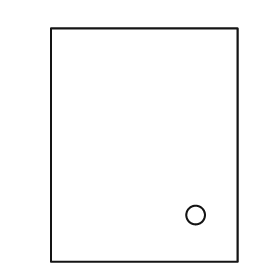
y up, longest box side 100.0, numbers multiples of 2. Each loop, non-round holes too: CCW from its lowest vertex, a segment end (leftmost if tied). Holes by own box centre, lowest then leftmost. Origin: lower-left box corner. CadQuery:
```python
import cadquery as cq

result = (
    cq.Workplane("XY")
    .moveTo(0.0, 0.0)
    .lineTo(80.0, 0.0)
    .lineTo(80.0, 100.0)
    .lineTo(0.0, 100.0)
    .close()
    .moveTo(62.0, 20.0)
    .circle(4.0)
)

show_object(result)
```